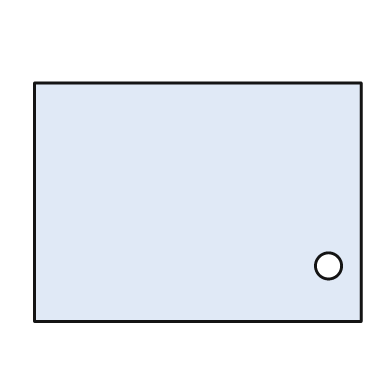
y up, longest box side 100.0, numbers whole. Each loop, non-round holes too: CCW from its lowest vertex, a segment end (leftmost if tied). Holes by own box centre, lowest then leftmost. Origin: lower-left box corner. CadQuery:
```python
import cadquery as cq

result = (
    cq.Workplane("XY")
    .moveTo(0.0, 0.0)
    .lineTo(100.0, 0.0)
    .lineTo(100.0, 73.0)
    .lineTo(0.0, 73.0)
    .close()
    .moveTo(90.0, 17.0)
    .circle(4.0)
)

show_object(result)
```